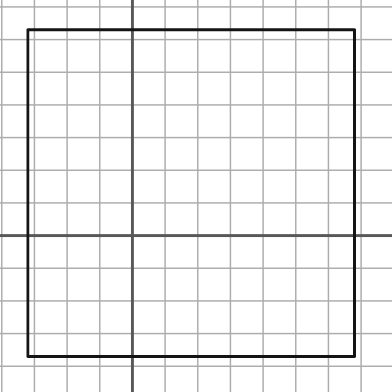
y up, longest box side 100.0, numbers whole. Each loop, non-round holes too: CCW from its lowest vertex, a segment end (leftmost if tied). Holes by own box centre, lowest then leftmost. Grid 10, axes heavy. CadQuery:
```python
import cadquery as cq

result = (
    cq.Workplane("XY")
    .moveTo(-32.0, -37.0)
    .lineTo(68.0, -37.0)
    .lineTo(68.0, 63.0)
    .lineTo(-32.0, 63.0)
    .close()
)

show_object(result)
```